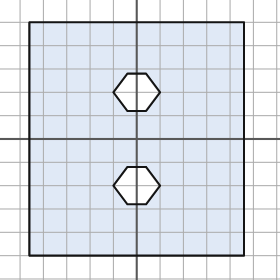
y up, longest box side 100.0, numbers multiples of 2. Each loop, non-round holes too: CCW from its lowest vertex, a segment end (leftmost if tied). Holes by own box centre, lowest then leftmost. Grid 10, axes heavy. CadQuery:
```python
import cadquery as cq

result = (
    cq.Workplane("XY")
    .moveTo(-46.0, -50.0)
    .lineTo(46.0, -50.0)
    .lineTo(46.0, 50.0)
    .lineTo(-46.0, 50.0)
    .close()
    .moveTo(-4.0, -28.0)
    .lineTo(4.0, -28.0)
    .lineTo(10.0, -20.0)
    .lineTo(4.0, -12.0)
    .lineTo(-4.0, -12.0)
    .lineTo(-10.0, -20.0)
    .close()
    .moveTo(-4.0, 12.0)
    .lineTo(4.0, 12.0)
    .lineTo(10.0, 20.0)
    .lineTo(4.0, 28.0)
    .lineTo(-4.0, 28.0)
    .lineTo(-10.0, 20.0)
    .close()
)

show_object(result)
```